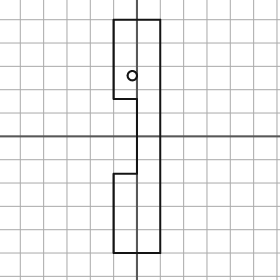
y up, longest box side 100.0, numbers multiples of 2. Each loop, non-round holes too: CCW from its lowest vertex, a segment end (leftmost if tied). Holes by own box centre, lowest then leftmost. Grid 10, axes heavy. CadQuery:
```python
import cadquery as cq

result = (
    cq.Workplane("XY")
    .moveTo(-10.0, -50.0)
    .lineTo(10.0, -50.0)
    .lineTo(10.0, 50.0)
    .lineTo(-10.0, 50.0)
    .lineTo(-10.0, 16.0)
    .lineTo(0.0, 16.0)
    .lineTo(0.0, -16.0)
    .lineTo(-10.0, -16.0)
    .close()
    .moveTo(-2.0, 26.0)
    .circle(2.0)
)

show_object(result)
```